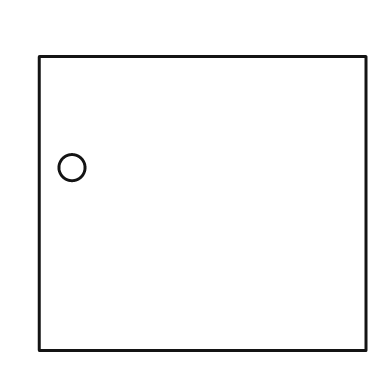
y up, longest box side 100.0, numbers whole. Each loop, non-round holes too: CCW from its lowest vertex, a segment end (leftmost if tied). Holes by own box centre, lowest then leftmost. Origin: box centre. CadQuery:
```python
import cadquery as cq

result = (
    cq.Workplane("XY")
    .moveTo(-50.0, -45.0)
    .lineTo(50.0, -45.0)
    .lineTo(50.0, 45.0)
    .lineTo(-50.0, 45.0)
    .close()
    .moveTo(-40.0, 11.0)
    .circle(4.0)
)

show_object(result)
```